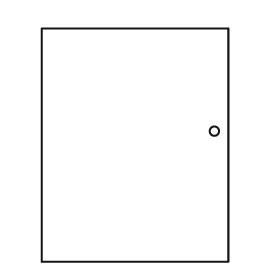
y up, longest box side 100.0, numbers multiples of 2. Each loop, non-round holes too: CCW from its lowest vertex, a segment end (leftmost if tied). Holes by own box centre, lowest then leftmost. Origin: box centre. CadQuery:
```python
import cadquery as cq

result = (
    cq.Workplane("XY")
    .moveTo(-40.0, -50.0)
    .lineTo(40.0, -50.0)
    .lineTo(40.0, 50.0)
    .lineTo(-40.0, 50.0)
    .close()
    .moveTo(34.0, 6.0)
    .circle(2.0)
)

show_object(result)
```